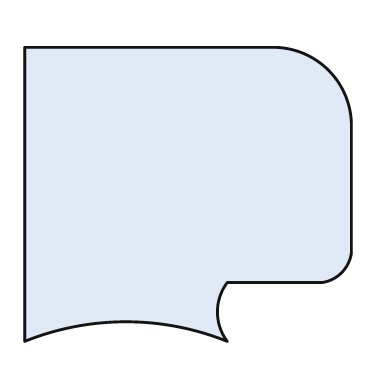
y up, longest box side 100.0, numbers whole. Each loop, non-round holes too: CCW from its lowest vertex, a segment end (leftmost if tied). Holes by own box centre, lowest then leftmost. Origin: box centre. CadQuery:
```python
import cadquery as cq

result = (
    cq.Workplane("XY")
    .moveTo(-50.0, -45.0)
    .threePointArc((-19.0, -39.0), (12.0, -45.0))
    .threePointArc((9.0, -36.0), (12.0, -27.0))
    .lineTo(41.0, -27.0)
    .threePointArc((47.0, -24.0), (50.0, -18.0))
    .lineTo(50.0, 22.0)
    .threePointArc((43.0, 38.0), (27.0, 45.0))
    .lineTo(-50.0, 45.0)
    .close()
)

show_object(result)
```